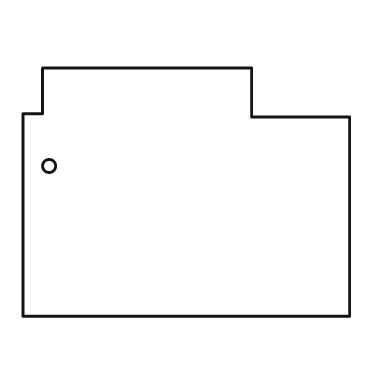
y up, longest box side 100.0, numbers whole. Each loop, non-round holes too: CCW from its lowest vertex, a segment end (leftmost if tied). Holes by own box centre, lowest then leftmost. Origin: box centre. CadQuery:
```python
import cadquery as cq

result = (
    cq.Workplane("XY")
    .moveTo(-50.0, -38.0)
    .lineTo(50.0, -38.0)
    .lineTo(50.0, 23.0)
    .lineTo(20.0, 23.0)
    .lineTo(20.0, 38.0)
    .lineTo(-44.0, 38.0)
    .lineTo(-44.0, 24.0)
    .lineTo(-50.0, 24.0)
    .close()
    .moveTo(-42.0, 8.0)
    .circle(2.0)
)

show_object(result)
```